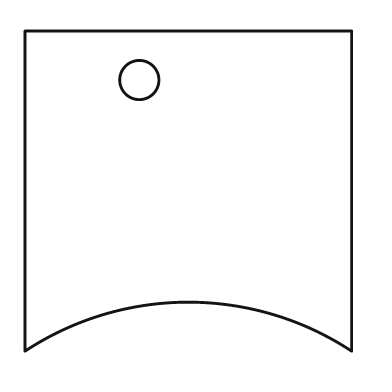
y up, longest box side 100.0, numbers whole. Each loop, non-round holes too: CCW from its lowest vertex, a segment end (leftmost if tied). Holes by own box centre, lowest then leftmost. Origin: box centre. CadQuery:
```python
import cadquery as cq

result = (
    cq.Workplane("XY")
    .moveTo(-50.0, -49.0)
    .threePointArc((0.0, -34.0), (50.0, -49.0))
    .lineTo(50.0, 49.0)
    .lineTo(-50.0, 49.0)
    .close()
    .moveTo(-15.0, 34.0)
    .circle(6.0)
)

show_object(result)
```